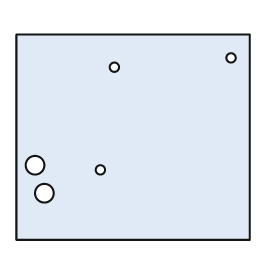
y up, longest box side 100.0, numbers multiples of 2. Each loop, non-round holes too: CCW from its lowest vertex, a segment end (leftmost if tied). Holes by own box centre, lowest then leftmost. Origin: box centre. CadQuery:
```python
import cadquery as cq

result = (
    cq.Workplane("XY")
    .moveTo(-50.0, -44.0)
    .lineTo(50.0, -44.0)
    .lineTo(50.0, 44.0)
    .lineTo(-50.0, 44.0)
    .close()
    .moveTo(-38.0, -24.0)
    .circle(4.0)
    .moveTo(-14.0, -14.0)
    .circle(2.0)
    .moveTo(-42.0, -12.0)
    .circle(4.0)
    .moveTo(-8.0, 30.0)
    .circle(2.0)
    .moveTo(42.0, 34.0)
    .circle(2.0)
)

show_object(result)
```